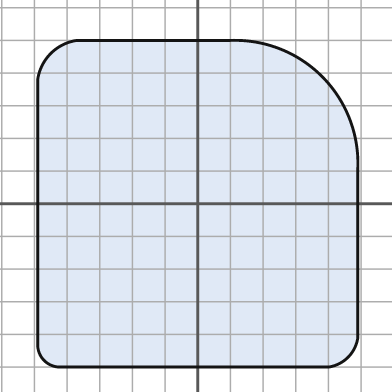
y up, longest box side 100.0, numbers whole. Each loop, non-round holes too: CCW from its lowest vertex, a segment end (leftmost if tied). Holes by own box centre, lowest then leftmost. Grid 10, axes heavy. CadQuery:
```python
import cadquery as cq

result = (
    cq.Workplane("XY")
    .moveTo(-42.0, -50.0)
    .lineTo(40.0, -50.0)
    .threePointArc((46.0, -47.0), (49.0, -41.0))
    .lineTo(49.0, 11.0)
    .threePointArc((38.0, 39.0), (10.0, 50.0))
    .lineTo(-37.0, 50.0)
    .threePointArc((-45.0, 46.0), (-49.0, 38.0))
    .lineTo(-49.0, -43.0)
    .threePointArc((-47.0, -48.0), (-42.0, -50.0))
    .close()
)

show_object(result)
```